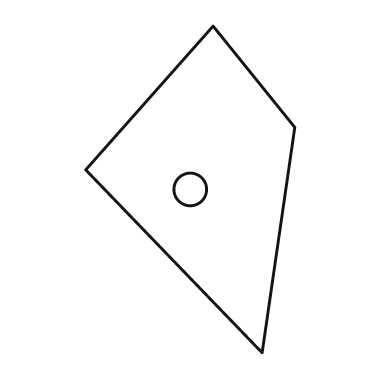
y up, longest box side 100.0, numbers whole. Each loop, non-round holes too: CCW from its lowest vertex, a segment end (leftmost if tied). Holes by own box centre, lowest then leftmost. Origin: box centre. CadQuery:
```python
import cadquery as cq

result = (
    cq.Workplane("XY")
    .moveTo(22.0, -50.0)
    .lineTo(32.0, 19.0)
    .lineTo(7.0, 50.0)
    .lineTo(-32.0, 6.0)
    .close()
    .moveTo(0.0, 0.0)
    .circle(5.0)
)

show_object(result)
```